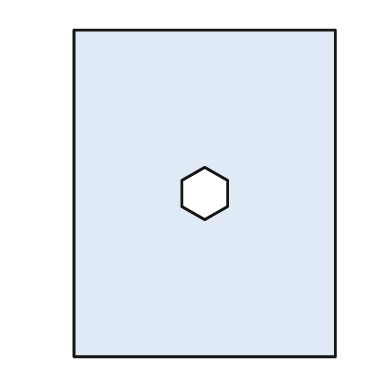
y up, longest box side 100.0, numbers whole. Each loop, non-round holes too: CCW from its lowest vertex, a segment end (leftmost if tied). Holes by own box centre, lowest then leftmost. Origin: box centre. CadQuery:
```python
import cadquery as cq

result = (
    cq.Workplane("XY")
    .moveTo(-40.0, -50.0)
    .lineTo(40.0, -50.0)
    .lineTo(40.0, 50.0)
    .lineTo(-40.0, 50.0)
    .close()
    .moveTo(0.0, -8.0)
    .lineTo(7.0, -4.0)
    .lineTo(7.0, 4.0)
    .lineTo(0.0, 8.0)
    .lineTo(-7.0, 4.0)
    .lineTo(-7.0, -4.0)
    .close()
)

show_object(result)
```